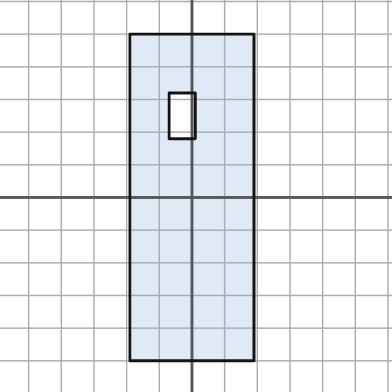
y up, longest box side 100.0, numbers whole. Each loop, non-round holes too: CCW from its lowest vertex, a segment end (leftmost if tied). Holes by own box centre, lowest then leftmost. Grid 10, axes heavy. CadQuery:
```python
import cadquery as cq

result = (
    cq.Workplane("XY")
    .moveTo(-19.0, -50.0)
    .lineTo(19.0, -50.0)
    .lineTo(19.0, 50.0)
    .lineTo(-19.0, 50.0)
    .close()
    .moveTo(-7.0, 18.0)
    .lineTo(1.0, 18.0)
    .lineTo(1.0, 32.0)
    .lineTo(-7.0, 32.0)
    .close()
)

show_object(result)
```